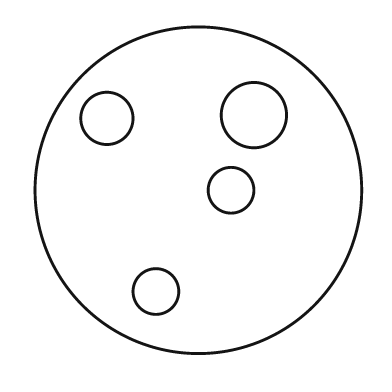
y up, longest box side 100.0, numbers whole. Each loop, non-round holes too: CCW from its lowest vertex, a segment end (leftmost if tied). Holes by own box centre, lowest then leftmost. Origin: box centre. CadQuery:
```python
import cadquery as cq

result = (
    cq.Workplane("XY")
    .moveTo(0.0, 0.0)
    .circle(50.0)
    .moveTo(-13.0, -31.0)
    .circle(7.0)
    .moveTo(10.0, 0.0)
    .circle(7.0)
    .moveTo(-28.0, 22.0)
    .circle(8.0)
    .moveTo(17.0, 23.0)
    .circle(10.0)
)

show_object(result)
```